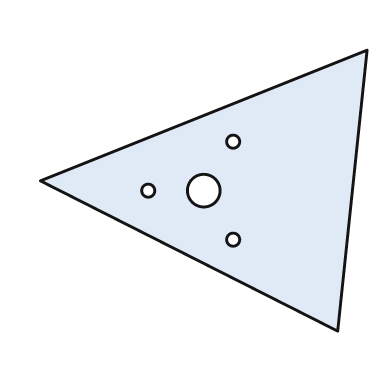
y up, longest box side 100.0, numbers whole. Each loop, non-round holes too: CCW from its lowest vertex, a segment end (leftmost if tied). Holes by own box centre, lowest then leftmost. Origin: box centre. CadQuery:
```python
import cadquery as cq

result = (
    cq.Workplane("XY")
    .moveTo(41.0, -43.0)
    .lineTo(50.0, 43.0)
    .lineTo(-50.0, 3.0)
    .close()
    .moveTo(9.0, -15.0)
    .circle(2.0)
    .moveTo(-17.0, 0.0)
    .circle(2.0)
    .moveTo(0.0, 0.0)
    .circle(5.0)
    .moveTo(9.0, 15.0)
    .circle(2.0)
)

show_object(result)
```